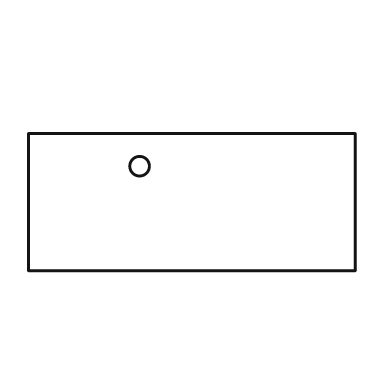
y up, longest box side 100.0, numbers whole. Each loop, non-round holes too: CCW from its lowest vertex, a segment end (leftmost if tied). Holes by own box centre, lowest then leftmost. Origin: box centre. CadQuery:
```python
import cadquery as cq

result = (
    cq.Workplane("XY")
    .moveTo(-50.0, -21.0)
    .lineTo(50.0, -21.0)
    .lineTo(50.0, 21.0)
    .lineTo(-50.0, 21.0)
    .close()
    .moveTo(-16.0, 11.0)
    .circle(3.0)
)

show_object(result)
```